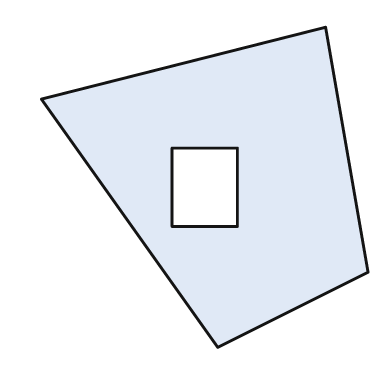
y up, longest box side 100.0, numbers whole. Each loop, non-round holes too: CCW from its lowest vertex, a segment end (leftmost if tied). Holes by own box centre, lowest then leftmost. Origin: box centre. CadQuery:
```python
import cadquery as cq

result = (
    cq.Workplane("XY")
    .moveTo(4.0, -49.0)
    .lineTo(50.0, -26.0)
    .lineTo(37.0, 49.0)
    .lineTo(-50.0, 27.0)
    .close()
    .moveTo(-10.0, -12.0)
    .lineTo(10.0, -12.0)
    .lineTo(10.0, 12.0)
    .lineTo(-10.0, 12.0)
    .close()
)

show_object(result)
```